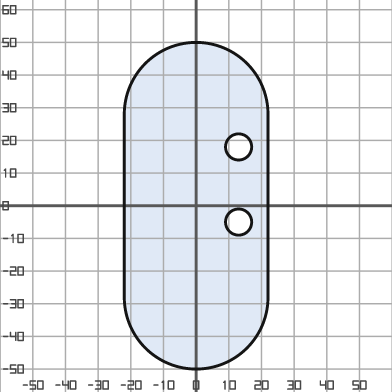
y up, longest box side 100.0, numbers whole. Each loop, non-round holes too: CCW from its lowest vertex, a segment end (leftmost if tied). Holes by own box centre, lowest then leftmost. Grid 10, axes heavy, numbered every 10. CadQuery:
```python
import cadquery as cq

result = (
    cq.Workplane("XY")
    .moveTo(-22.0, -28.0)
    .threePointArc((0.0, -50.0), (22.0, -28.0))
    .lineTo(22.0, 28.0)
    .threePointArc((0.0, 50.0), (-22.0, 28.0))
    .close()
    .moveTo(13.0, -5.0)
    .circle(4.0)
    .moveTo(13.0, 18.0)
    .circle(4.0)
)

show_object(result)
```